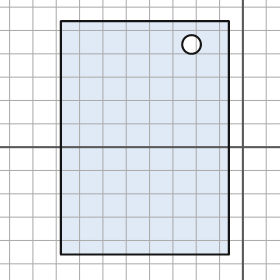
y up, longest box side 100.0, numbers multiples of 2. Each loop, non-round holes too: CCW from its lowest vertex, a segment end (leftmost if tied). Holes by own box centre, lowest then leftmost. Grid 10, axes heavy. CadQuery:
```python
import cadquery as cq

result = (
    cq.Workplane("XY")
    .moveTo(-78.0, -46.0)
    .lineTo(-6.0, -46.0)
    .lineTo(-6.0, 54.0)
    .lineTo(-78.0, 54.0)
    .close()
    .moveTo(-22.0, 44.0)
    .circle(4.0)
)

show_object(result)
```